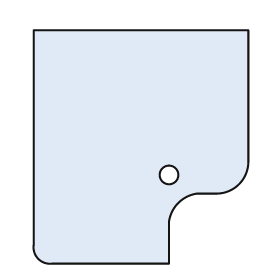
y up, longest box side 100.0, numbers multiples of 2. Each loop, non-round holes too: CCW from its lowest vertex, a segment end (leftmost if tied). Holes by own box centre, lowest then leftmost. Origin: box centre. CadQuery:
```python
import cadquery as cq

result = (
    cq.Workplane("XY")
    .moveTo(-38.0, -50.0)
    .lineTo(12.0, -50.0)
    .lineTo(12.0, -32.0)
    .threePointArc((16.0, -24.0), (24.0, -20.0))
    .lineTo(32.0, -20.0)
    .threePointArc((42.0, -16.0), (46.0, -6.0))
    .lineTo(46.0, 50.0)
    .lineTo(-46.0, 50.0)
    .lineTo(-46.0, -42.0)
    .threePointArc((-44.0, -48.0), (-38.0, -50.0))
    .close()
    .moveTo(12.0, -12.0)
    .circle(4.0)
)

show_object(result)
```